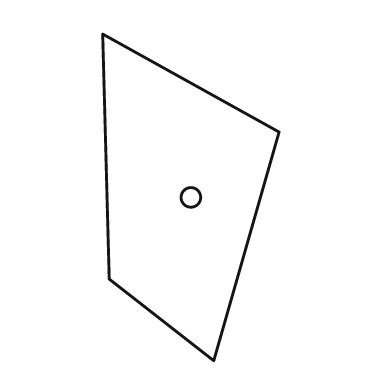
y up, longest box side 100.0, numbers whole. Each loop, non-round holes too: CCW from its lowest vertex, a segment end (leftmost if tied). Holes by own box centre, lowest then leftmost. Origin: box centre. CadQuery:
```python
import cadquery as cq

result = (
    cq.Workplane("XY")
    .moveTo(7.0, -50.0)
    .lineTo(27.0, 20.0)
    .lineTo(-27.0, 50.0)
    .lineTo(-25.0, -25.0)
    .close()
    .moveTo(0.0, 0.0)
    .circle(3.0)
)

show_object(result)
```